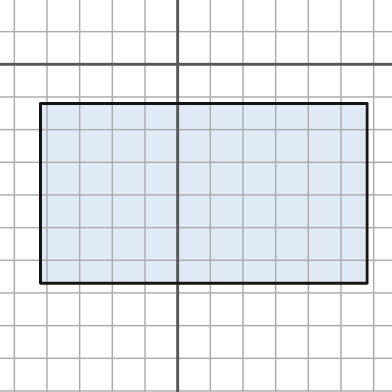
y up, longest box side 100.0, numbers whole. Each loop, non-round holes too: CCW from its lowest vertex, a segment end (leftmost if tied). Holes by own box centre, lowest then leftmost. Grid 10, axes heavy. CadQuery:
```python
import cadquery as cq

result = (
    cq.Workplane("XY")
    .moveTo(-42.0, -67.0)
    .lineTo(58.0, -67.0)
    .lineTo(58.0, -12.0)
    .lineTo(-42.0, -12.0)
    .close()
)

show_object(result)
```